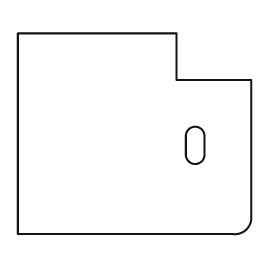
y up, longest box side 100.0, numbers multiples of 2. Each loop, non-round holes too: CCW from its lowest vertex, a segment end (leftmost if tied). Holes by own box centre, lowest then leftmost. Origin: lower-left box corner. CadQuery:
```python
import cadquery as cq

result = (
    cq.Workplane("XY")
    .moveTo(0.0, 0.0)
    .lineTo(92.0, 0.0)
    .threePointArc((98.0, 2.0), (100.0, 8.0))
    .lineTo(100.0, 66.0)
    .lineTo(68.0, 66.0)
    .lineTo(68.0, 86.0)
    .lineTo(0.0, 86.0)
    .close()
    .moveTo(72.0, 34.0)
    .threePointArc((76.0, 30.0), (80.0, 34.0))
    .lineTo(80.0, 42.0)
    .threePointArc((76.0, 46.0), (72.0, 42.0))
    .close()
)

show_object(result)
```